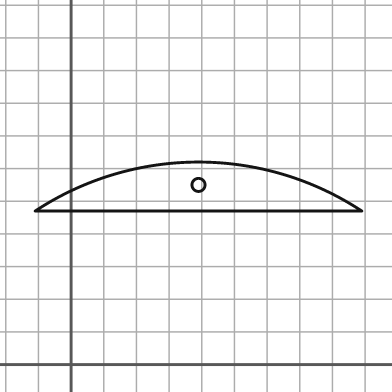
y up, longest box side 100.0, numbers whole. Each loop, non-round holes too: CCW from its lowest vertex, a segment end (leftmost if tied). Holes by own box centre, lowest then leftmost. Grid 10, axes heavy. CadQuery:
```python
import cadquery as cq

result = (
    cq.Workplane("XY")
    .moveTo(-11.0, 47.0)
    .lineTo(89.0, 47.0)
    .threePointArc((39.0, 62.0), (-11.0, 47.0))
    .close()
    .moveTo(39.0, 55.0)
    .circle(2.0)
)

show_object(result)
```